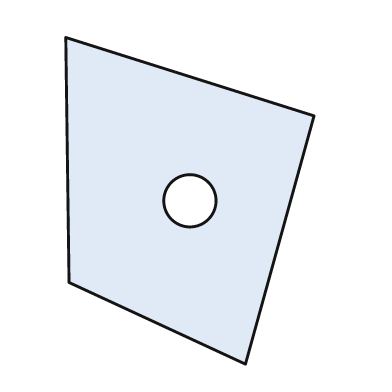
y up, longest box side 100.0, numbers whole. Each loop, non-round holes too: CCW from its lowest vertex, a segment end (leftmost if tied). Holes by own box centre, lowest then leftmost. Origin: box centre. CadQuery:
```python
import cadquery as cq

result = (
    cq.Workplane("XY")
    .moveTo(17.0, -50.0)
    .lineTo(38.0, 26.0)
    .lineTo(-38.0, 50.0)
    .lineTo(-37.0, -25.0)
    .close()
    .moveTo(0.0, 0.0)
    .circle(8.0)
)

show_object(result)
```